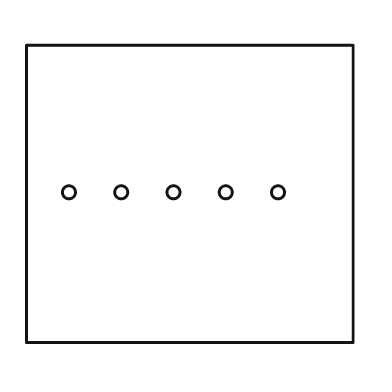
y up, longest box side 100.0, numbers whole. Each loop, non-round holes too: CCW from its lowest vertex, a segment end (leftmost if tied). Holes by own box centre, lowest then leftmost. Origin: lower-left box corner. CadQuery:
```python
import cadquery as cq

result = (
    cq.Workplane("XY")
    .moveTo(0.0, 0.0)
    .lineTo(100.0, 0.0)
    .lineTo(100.0, 91.0)
    .lineTo(0.0, 91.0)
    .close()
    .moveTo(13.0, 46.0)
    .circle(2.0)
    .moveTo(29.0, 46.0)
    .circle(2.0)
    .moveTo(45.0, 46.0)
    .circle(2.0)
    .moveTo(61.0, 46.0)
    .circle(2.0)
    .moveTo(77.0, 46.0)
    .circle(2.0)
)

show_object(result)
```